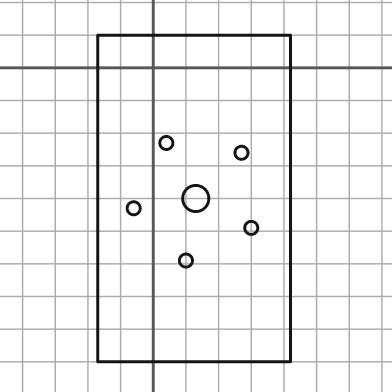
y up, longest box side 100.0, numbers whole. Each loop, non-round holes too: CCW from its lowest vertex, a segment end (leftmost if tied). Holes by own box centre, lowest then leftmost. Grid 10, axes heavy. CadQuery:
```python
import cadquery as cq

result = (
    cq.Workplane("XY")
    .moveTo(-17.0, -90.0)
    .lineTo(42.0, -90.0)
    .lineTo(42.0, 10.0)
    .lineTo(-17.0, 10.0)
    .close()
    .moveTo(10.0, -59.0)
    .circle(2.0)
    .moveTo(30.0, -49.0)
    .circle(2.0)
    .moveTo(-6.0, -43.0)
    .circle(2.0)
    .moveTo(13.0, -40.0)
    .circle(4.0)
    .moveTo(27.0, -26.0)
    .circle(2.0)
    .moveTo(4.0, -23.0)
    .circle(2.0)
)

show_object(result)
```